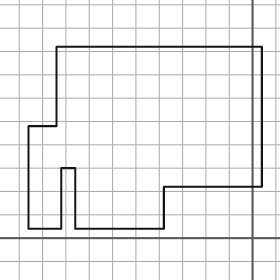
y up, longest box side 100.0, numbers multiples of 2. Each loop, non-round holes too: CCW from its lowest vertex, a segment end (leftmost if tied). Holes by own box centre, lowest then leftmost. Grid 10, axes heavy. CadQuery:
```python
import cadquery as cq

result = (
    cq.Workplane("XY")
    .moveTo(-96.0, 4.0)
    .lineTo(-82.0, 4.0)
    .lineTo(-82.0, 30.0)
    .lineTo(-76.0, 30.0)
    .lineTo(-76.0, 4.0)
    .lineTo(-38.0, 4.0)
    .lineTo(-38.0, 22.0)
    .lineTo(4.0, 22.0)
    .lineTo(4.0, 82.0)
    .lineTo(-84.0, 82.0)
    .lineTo(-84.0, 48.0)
    .lineTo(-96.0, 48.0)
    .close()
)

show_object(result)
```